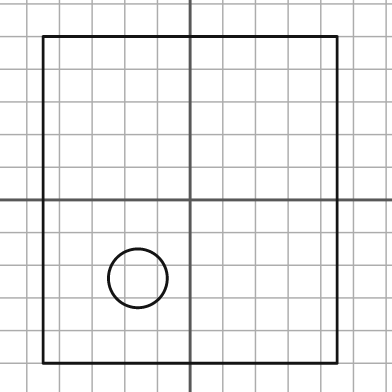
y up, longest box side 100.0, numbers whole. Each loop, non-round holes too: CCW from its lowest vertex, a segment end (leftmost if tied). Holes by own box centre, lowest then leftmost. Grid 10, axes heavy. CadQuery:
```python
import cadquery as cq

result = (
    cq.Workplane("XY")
    .moveTo(-45.0, -50.0)
    .lineTo(45.0, -50.0)
    .lineTo(45.0, 50.0)
    .lineTo(-45.0, 50.0)
    .close()
    .moveTo(-16.0, -24.0)
    .circle(9.0)
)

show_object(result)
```